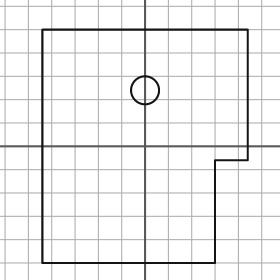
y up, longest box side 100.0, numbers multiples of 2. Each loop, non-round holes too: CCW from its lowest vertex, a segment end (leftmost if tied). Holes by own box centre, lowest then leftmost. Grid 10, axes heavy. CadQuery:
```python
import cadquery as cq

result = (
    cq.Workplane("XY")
    .moveTo(-44.0, -50.0)
    .lineTo(30.0, -50.0)
    .lineTo(30.0, -6.0)
    .lineTo(44.0, -6.0)
    .lineTo(44.0, 50.0)
    .lineTo(-44.0, 50.0)
    .close()
    .moveTo(0.0, 24.0)
    .circle(6.0)
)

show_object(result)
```